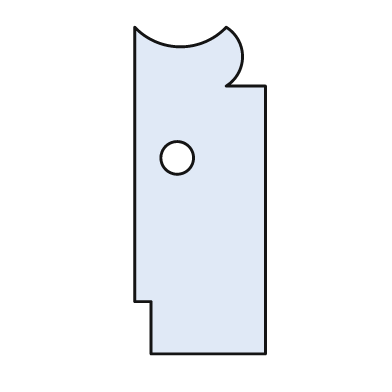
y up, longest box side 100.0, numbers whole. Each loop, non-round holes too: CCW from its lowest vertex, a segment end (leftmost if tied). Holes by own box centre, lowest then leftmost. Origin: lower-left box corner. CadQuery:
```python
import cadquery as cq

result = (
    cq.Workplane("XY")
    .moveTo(5.0, 0.0)
    .lineTo(40.0, 0.0)
    .lineTo(40.0, 82.0)
    .lineTo(28.0, 82.0)
    .threePointArc((33.0, 91.0), (28.0, 100.0))
    .threePointArc((14.0, 94.0), (0.0, 100.0))
    .lineTo(0.0, 16.0)
    .lineTo(5.0, 16.0)
    .close()
    .moveTo(13.0, 60.0)
    .circle(5.0)
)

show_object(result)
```